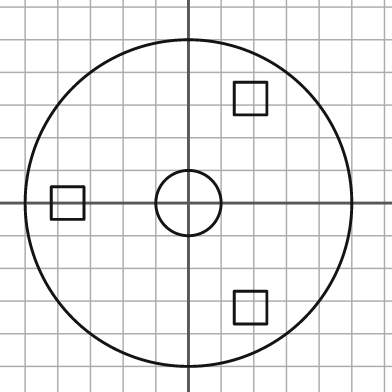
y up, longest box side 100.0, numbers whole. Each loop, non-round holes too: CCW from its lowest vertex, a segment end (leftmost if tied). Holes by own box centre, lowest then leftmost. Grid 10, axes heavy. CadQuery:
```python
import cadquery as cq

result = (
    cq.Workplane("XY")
    .moveTo(0.0, 0.0)
    .circle(50.0)
    .moveTo(14.0, -37.0)
    .lineTo(24.0, -37.0)
    .lineTo(24.0, -27.0)
    .lineTo(14.0, -27.0)
    .close()
    .moveTo(-42.0, -5.0)
    .lineTo(-32.0, -5.0)
    .lineTo(-32.0, 5.0)
    .lineTo(-42.0, 5.0)
    .close()
    .moveTo(0.0, 0.0)
    .circle(10.0)
    .moveTo(14.0, 27.0)
    .lineTo(24.0, 27.0)
    .lineTo(24.0, 37.0)
    .lineTo(14.0, 37.0)
    .close()
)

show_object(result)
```